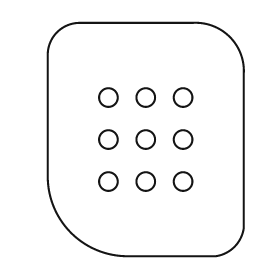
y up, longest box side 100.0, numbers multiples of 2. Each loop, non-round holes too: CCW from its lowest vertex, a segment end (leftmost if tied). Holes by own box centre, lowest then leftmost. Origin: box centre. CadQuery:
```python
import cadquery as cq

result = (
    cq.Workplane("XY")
    .moveTo(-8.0, -50.0)
    .lineTo(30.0, -50.0)
    .threePointArc((38.0, -46.0), (42.0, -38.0))
    .lineTo(42.0, 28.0)
    .threePointArc((36.0, 44.0), (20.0, 50.0))
    .lineTo(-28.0, 50.0)
    .threePointArc((-38.0, 46.0), (-42.0, 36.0))
    .lineTo(-42.0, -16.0)
    .threePointArc((-32.0, -40.0), (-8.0, -50.0))
    .close()
    .moveTo(-16.0, -18.0)
    .circle(4.0)
    .moveTo(0.0, -18.0)
    .circle(4.0)
    .moveTo(16.0, -18.0)
    .circle(4.0)
    .moveTo(-16.0, 0.0)
    .circle(4.0)
    .moveTo(0.0, 0.0)
    .circle(4.0)
    .moveTo(16.0, 0.0)
    .circle(4.0)
    .moveTo(-16.0, 18.0)
    .circle(4.0)
    .moveTo(0.0, 18.0)
    .circle(4.0)
    .moveTo(16.0, 18.0)
    .circle(4.0)
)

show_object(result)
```